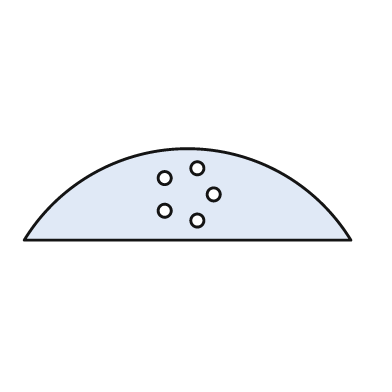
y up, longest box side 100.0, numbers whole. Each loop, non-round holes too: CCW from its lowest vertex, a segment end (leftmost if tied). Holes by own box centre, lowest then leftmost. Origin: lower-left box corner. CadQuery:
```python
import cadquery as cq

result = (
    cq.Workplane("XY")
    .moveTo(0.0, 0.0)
    .lineTo(100.0, 0.0)
    .threePointArc((50.0, 28.0), (0.0, 0.0))
    .close()
    .moveTo(53.0, 6.0)
    .circle(2.0)
    .moveTo(43.0, 9.0)
    .circle(2.0)
    .moveTo(58.0, 14.0)
    .circle(2.0)
    .moveTo(43.0, 19.0)
    .circle(2.0)
    .moveTo(53.0, 22.0)
    .circle(2.0)
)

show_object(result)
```